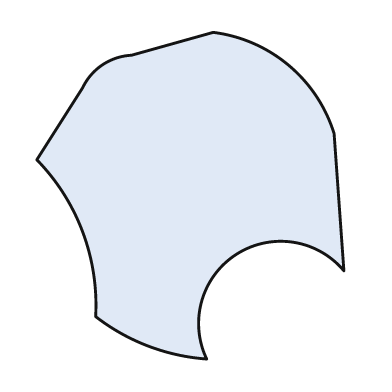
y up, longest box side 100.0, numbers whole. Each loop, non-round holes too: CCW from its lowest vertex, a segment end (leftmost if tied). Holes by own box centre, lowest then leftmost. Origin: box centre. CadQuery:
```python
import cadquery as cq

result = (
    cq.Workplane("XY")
    .moveTo(5.0, -50.0)
    .threePointArc((14.0, -18.0), (47.0, -23.0))
    .lineTo(44.0, 19.0)
    .threePointArc((30.0, 40.0), (7.0, 50.0))
    .lineTo(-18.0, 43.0)
    .threePointArc((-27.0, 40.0), (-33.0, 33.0))
    .lineTo(-47.0, 11.0)
    .threePointArc((-33.0, -11.0), (-29.0, -37.0))
    .threePointArc((-13.0, -46.0), (5.0, -50.0))
    .close()
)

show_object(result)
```